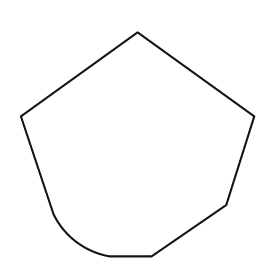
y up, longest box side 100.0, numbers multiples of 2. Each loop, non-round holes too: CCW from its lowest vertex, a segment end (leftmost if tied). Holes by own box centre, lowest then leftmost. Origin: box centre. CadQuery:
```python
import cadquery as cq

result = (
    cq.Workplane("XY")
    .moveTo(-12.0, -48.0)
    .lineTo(6.0, -48.0)
    .lineTo(38.0, -26.0)
    .lineTo(50.0, 12.0)
    .lineTo(0.0, 48.0)
    .lineTo(-50.0, 12.0)
    .lineTo(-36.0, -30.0)
    .threePointArc((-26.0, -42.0), (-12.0, -48.0))
    .close()
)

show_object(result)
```